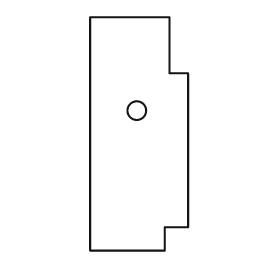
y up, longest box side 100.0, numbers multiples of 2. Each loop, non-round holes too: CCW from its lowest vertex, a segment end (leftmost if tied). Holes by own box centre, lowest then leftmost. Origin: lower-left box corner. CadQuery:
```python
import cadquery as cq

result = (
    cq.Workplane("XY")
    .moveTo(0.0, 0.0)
    .lineTo(32.0, 0.0)
    .lineTo(32.0, 10.0)
    .lineTo(42.0, 10.0)
    .lineTo(42.0, 76.0)
    .lineTo(34.0, 76.0)
    .lineTo(34.0, 100.0)
    .lineTo(0.0, 100.0)
    .close()
    .moveTo(20.0, 60.0)
    .circle(4.0)
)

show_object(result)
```